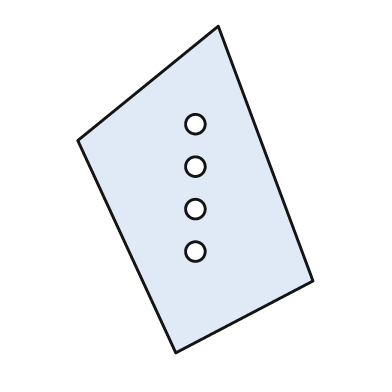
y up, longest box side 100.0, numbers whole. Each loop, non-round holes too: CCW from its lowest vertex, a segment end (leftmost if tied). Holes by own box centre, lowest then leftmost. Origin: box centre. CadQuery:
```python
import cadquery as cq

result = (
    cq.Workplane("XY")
    .moveTo(-6.0, -50.0)
    .lineTo(36.0, -28.0)
    .lineTo(7.0, 50.0)
    .lineTo(-36.0, 15.0)
    .close()
    .moveTo(0.0, -19.0)
    .circle(3.0)
    .moveTo(0.0, -6.0)
    .circle(3.0)
    .moveTo(0.0, 7.0)
    .circle(3.0)
    .moveTo(0.0, 20.0)
    .circle(3.0)
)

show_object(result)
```